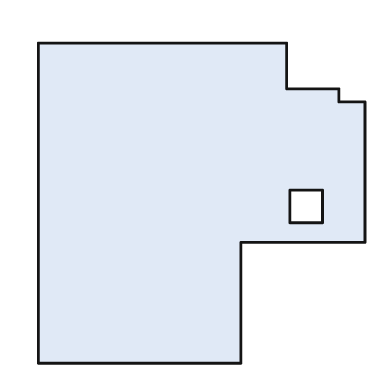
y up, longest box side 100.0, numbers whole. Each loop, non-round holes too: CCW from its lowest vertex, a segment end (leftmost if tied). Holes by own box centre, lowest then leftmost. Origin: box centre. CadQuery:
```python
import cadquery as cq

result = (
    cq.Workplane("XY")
    .moveTo(-50.0, -49.0)
    .lineTo(12.0, -49.0)
    .lineTo(12.0, -12.0)
    .lineTo(50.0, -12.0)
    .lineTo(50.0, 31.0)
    .lineTo(42.0, 31.0)
    .lineTo(42.0, 35.0)
    .lineTo(26.0, 35.0)
    .lineTo(26.0, 49.0)
    .lineTo(-50.0, 49.0)
    .close()
    .moveTo(27.0, -6.0)
    .lineTo(37.0, -6.0)
    .lineTo(37.0, 4.0)
    .lineTo(27.0, 4.0)
    .close()
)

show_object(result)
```